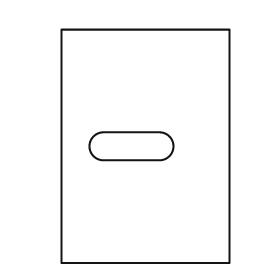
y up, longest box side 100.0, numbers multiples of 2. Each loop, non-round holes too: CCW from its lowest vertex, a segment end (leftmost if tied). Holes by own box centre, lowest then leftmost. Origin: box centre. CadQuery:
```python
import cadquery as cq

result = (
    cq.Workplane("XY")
    .moveTo(-36.0, -50.0)
    .lineTo(36.0, -50.0)
    .lineTo(36.0, 50.0)
    .lineTo(-36.0, 50.0)
    .close()
    .moveTo(-18.0, -6.0)
    .lineTo(6.0, -6.0)
    .threePointArc((12.0, 0.0), (6.0, 6.0))
    .lineTo(-18.0, 6.0)
    .threePointArc((-24.0, 0.0), (-18.0, -6.0))
    .close()
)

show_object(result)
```